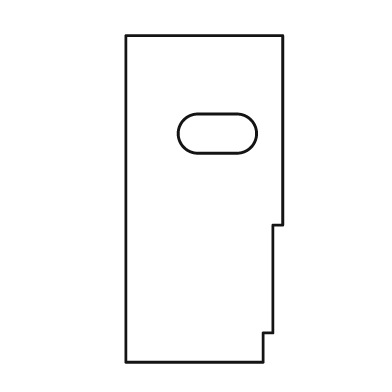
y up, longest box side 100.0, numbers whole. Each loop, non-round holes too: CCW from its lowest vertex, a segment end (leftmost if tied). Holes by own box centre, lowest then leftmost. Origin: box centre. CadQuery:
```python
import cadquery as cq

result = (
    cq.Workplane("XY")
    .moveTo(-24.0, -50.0)
    .lineTo(18.0, -50.0)
    .lineTo(18.0, -41.0)
    .lineTo(21.0, -41.0)
    .lineTo(21.0, -8.0)
    .lineTo(24.0, -8.0)
    .lineTo(24.0, 50.0)
    .lineTo(-24.0, 50.0)
    .close()
    .moveTo(-2.0, 14.0)
    .lineTo(10.0, 14.0)
    .threePointArc((16.0, 20.0), (10.0, 26.0))
    .lineTo(-2.0, 26.0)
    .threePointArc((-8.0, 20.0), (-2.0, 14.0))
    .close()
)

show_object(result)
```